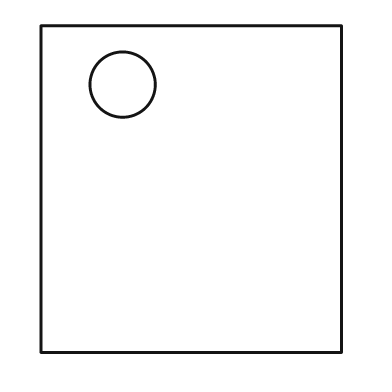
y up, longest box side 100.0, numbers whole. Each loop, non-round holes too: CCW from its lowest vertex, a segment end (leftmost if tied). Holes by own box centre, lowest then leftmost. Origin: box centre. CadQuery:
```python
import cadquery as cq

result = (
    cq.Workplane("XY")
    .moveTo(-46.0, -50.0)
    .lineTo(46.0, -50.0)
    .lineTo(46.0, 50.0)
    .lineTo(-46.0, 50.0)
    .close()
    .moveTo(-21.0, 32.0)
    .circle(10.0)
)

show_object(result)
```